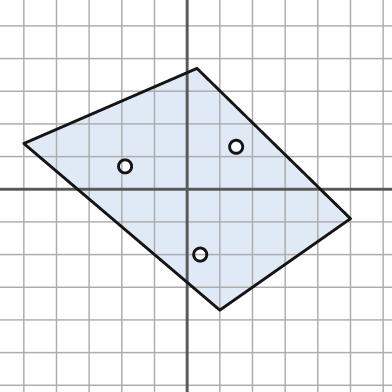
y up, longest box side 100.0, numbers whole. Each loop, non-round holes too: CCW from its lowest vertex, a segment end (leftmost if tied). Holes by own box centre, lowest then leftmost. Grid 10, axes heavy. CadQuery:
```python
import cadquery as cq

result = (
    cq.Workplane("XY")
    .moveTo(10.0, -37.0)
    .lineTo(50.0, -9.0)
    .lineTo(3.0, 37.0)
    .lineTo(-50.0, 14.0)
    .close()
    .moveTo(4.0, -20.0)
    .circle(2.0)
    .moveTo(-19.0, 7.0)
    .circle(2.0)
    .moveTo(15.0, 13.0)
    .circle(2.0)
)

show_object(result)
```